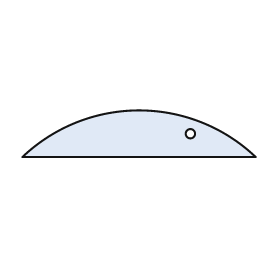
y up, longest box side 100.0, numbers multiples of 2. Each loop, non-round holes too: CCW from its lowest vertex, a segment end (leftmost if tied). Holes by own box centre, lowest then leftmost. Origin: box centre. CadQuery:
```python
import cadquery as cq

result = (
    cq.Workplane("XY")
    .moveTo(-50.0, -10.0)
    .lineTo(50.0, -10.0)
    .threePointArc((0.0, 10.0), (-50.0, -10.0))
    .close()
    .moveTo(22.0, 0.0)
    .circle(2.0)
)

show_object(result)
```